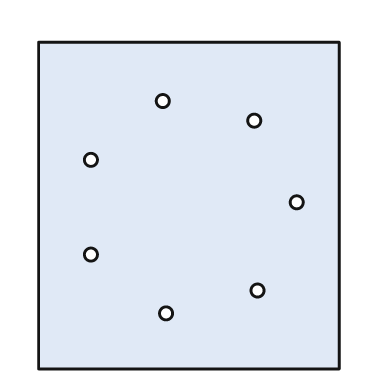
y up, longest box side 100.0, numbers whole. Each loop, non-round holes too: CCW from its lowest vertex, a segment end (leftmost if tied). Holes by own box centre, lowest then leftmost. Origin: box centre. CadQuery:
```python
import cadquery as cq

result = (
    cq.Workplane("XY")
    .moveTo(-46.0, -50.0)
    .lineTo(46.0, -50.0)
    .lineTo(46.0, 50.0)
    .lineTo(-46.0, 50.0)
    .close()
    .moveTo(-7.0, -33.0)
    .circle(2.0)
    .moveTo(21.0, -26.0)
    .circle(2.0)
    .moveTo(-30.0, -15.0)
    .circle(2.0)
    .moveTo(33.0, 1.0)
    .circle(2.0)
    .moveTo(-30.0, 14.0)
    .circle(2.0)
    .moveTo(20.0, 26.0)
    .circle(2.0)
    .moveTo(-8.0, 32.0)
    .circle(2.0)
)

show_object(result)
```